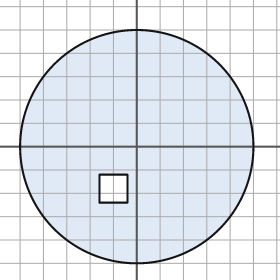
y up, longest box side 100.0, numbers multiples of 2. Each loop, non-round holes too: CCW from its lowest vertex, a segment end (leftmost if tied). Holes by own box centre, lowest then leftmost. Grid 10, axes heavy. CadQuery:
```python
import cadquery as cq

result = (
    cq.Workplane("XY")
    .moveTo(0.0, 0.0)
    .circle(50.0)
    .moveTo(-16.0, -24.0)
    .lineTo(-4.0, -24.0)
    .lineTo(-4.0, -12.0)
    .lineTo(-16.0, -12.0)
    .close()
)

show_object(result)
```